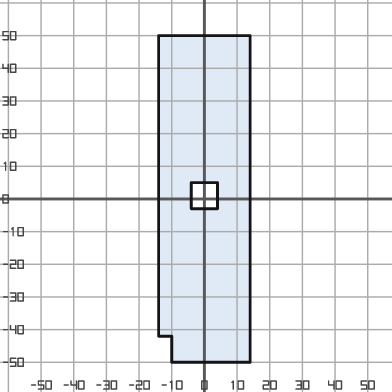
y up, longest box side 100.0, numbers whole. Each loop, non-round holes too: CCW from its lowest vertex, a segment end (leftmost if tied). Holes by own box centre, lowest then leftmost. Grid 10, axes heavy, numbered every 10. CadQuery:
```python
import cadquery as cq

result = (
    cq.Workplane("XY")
    .moveTo(-10.0, -50.0)
    .lineTo(14.0, -50.0)
    .lineTo(14.0, 50.0)
    .lineTo(-14.0, 50.0)
    .lineTo(-14.0, -42.0)
    .lineTo(-10.0, -42.0)
    .close()
    .moveTo(-4.0, -3.0)
    .lineTo(4.0, -3.0)
    .lineTo(4.0, 5.0)
    .lineTo(-4.0, 5.0)
    .close()
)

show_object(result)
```